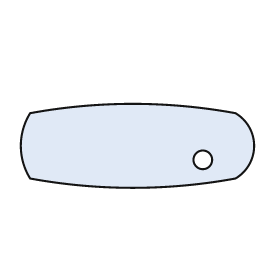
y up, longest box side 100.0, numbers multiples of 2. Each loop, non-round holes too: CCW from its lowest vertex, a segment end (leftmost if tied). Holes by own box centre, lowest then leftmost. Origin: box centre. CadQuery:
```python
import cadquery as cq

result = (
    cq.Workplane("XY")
    .moveTo(-46.0, -14.0)
    .threePointArc((-2.0, -18.0), (42.0, -14.0))
    .threePointArc((50.0, 0.0), (42.0, 14.0))
    .threePointArc((-2.0, 18.0), (-46.0, 14.0))
    .threePointArc((-50.0, 0.0), (-46.0, -14.0))
    .close()
    .moveTo(28.0, -6.0)
    .circle(4.0)
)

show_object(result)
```